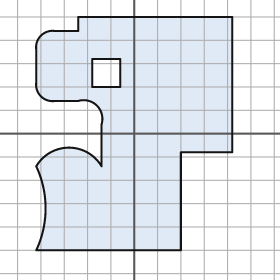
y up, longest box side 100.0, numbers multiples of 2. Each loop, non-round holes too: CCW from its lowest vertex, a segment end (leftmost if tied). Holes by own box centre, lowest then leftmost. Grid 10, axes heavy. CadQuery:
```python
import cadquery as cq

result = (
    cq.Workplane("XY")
    .moveTo(-42.0, -50.0)
    .lineTo(20.0, -50.0)
    .lineTo(20.0, -8.0)
    .lineTo(42.0, -8.0)
    .lineTo(42.0, 50.0)
    .lineTo(-24.0, 50.0)
    .lineTo(-24.0, 44.0)
    .lineTo(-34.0, 44.0)
    .threePointArc((-40.0, 42.0), (-42.0, 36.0))
    .lineTo(-42.0, 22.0)
    .threePointArc((-40.0, 16.0), (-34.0, 14.0))
    .lineTo(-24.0, 14.0)
    .threePointArc((-16.0, 12.0), (-14.0, 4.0))
    .lineTo(-14.0, -14.0)
    .threePointArc((-28.0, -6.0), (-42.0, -14.0))
    .threePointArc((-38.0, -32.0), (-42.0, -50.0))
    .close()
    .moveTo(-18.0, 20.0)
    .lineTo(-6.0, 20.0)
    .lineTo(-6.0, 32.0)
    .lineTo(-18.0, 32.0)
    .close()
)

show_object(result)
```